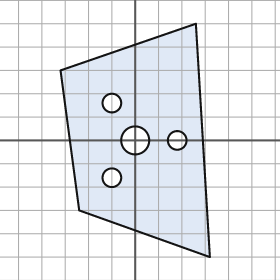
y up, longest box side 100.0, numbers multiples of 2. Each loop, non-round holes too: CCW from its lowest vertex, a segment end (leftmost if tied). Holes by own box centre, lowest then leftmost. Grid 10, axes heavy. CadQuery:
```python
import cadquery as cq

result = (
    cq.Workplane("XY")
    .moveTo(32.0, -50.0)
    .lineTo(26.0, 50.0)
    .lineTo(-32.0, 30.0)
    .lineTo(-24.0, -30.0)
    .close()
    .moveTo(-10.0, -16.0)
    .circle(4.0)
    .moveTo(0.0, 0.0)
    .circle(6.0)
    .moveTo(18.0, 0.0)
    .circle(4.0)
    .moveTo(-10.0, 16.0)
    .circle(4.0)
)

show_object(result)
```